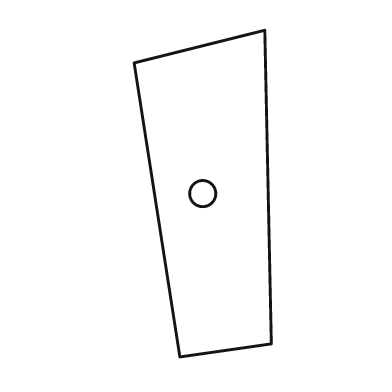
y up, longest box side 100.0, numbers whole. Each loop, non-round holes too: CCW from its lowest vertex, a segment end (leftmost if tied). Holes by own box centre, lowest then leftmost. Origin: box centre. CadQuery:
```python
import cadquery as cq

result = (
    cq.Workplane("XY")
    .moveTo(-7.0, -50.0)
    .lineTo(21.0, -46.0)
    .lineTo(19.0, 50.0)
    .lineTo(-21.0, 40.0)
    .close()
    .moveTo(0.0, 0.0)
    .circle(4.0)
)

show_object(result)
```